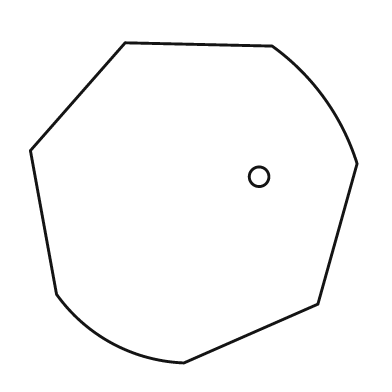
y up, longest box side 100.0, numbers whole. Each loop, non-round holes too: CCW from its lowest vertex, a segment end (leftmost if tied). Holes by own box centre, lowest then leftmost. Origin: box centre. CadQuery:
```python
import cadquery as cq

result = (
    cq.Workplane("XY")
    .moveTo(-3.0, -49.0)
    .lineTo(38.0, -31.0)
    .lineTo(50.0, 12.0)
    .threePointArc((40.0, 32.0), (24.0, 48.0))
    .lineTo(-21.0, 49.0)
    .lineTo(-50.0, 16.0)
    .lineTo(-42.0, -28.0)
    .threePointArc((-25.0, -43.0), (-3.0, -49.0))
    .close()
    .moveTo(20.0, 8.0)
    .circle(3.0)
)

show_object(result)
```